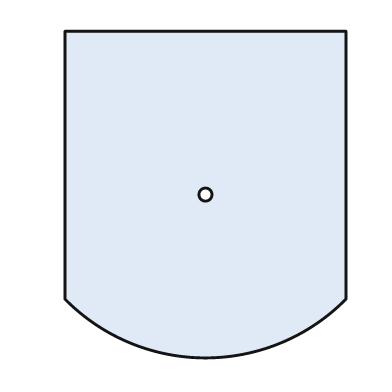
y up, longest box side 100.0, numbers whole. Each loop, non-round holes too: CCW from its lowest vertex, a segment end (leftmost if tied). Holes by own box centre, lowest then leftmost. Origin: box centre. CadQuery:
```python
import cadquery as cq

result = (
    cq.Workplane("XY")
    .moveTo(-43.0, -32.0)
    .threePointArc((0.0, -50.0), (43.0, -32.0))
    .lineTo(43.0, 50.0)
    .lineTo(-43.0, 50.0)
    .close()
    .moveTo(0.0, 0.0)
    .circle(2.0)
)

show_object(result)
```